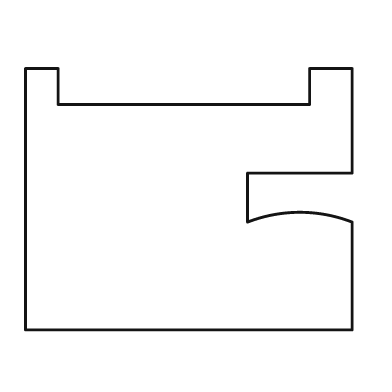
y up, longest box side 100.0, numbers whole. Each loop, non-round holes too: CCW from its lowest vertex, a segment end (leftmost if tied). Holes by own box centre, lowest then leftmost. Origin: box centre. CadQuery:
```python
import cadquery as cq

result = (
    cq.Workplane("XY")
    .moveTo(-50.0, -40.0)
    .lineTo(50.0, -40.0)
    .lineTo(50.0, -7.0)
    .threePointArc((34.0, -4.0), (18.0, -7.0))
    .lineTo(18.0, 8.0)
    .lineTo(50.0, 8.0)
    .lineTo(50.0, 40.0)
    .lineTo(37.0, 40.0)
    .lineTo(37.0, 29.0)
    .lineTo(-40.0, 29.0)
    .lineTo(-40.0, 40.0)
    .lineTo(-50.0, 40.0)
    .close()
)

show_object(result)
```